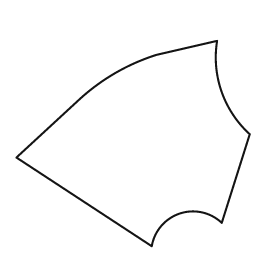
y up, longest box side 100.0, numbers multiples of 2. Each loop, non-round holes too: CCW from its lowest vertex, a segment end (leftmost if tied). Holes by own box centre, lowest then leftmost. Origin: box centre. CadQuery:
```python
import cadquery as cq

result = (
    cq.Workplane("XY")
    .moveTo(8.0, -44.0)
    .threePointArc((20.0, -30.0), (38.0, -34.0))
    .lineTo(50.0, 4.0)
    .threePointArc((38.0, 22.0), (36.0, 44.0))
    .lineTo(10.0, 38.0)
    .threePointArc((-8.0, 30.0), (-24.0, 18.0))
    .lineTo(-50.0, -6.0)
    .close()
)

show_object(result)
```